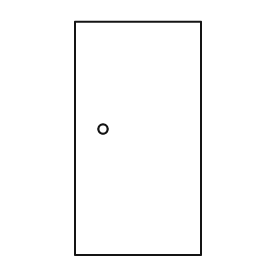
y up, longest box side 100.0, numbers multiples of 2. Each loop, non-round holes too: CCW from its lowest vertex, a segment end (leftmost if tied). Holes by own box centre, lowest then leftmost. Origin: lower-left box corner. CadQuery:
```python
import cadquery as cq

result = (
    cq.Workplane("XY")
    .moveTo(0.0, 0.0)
    .lineTo(54.0, 0.0)
    .lineTo(54.0, 100.0)
    .lineTo(0.0, 100.0)
    .close()
    .moveTo(12.0, 54.0)
    .circle(2.0)
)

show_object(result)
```